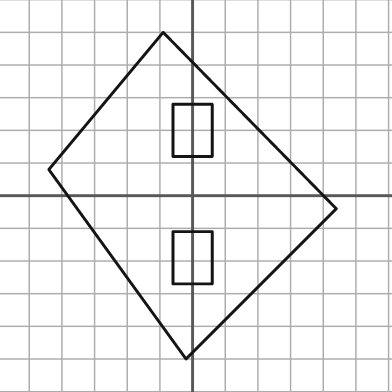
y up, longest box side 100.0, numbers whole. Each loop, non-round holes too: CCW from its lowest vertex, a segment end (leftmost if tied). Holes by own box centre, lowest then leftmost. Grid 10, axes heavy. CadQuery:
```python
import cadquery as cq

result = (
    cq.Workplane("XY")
    .moveTo(-2.0, -50.0)
    .lineTo(44.0, -4.0)
    .lineTo(-9.0, 50.0)
    .lineTo(-44.0, 8.0)
    .close()
    .moveTo(-6.0, -27.0)
    .lineTo(6.0, -27.0)
    .lineTo(6.0, -11.0)
    .lineTo(-6.0, -11.0)
    .close()
    .moveTo(-6.0, 12.0)
    .lineTo(6.0, 12.0)
    .lineTo(6.0, 28.0)
    .lineTo(-6.0, 28.0)
    .close()
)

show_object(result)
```